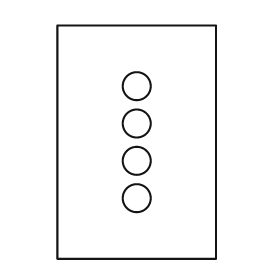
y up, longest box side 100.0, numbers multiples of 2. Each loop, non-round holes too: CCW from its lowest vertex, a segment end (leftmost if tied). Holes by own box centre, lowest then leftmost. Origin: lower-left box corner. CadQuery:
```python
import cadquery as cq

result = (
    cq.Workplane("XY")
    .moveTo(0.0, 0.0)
    .lineTo(68.0, 0.0)
    .lineTo(68.0, 100.0)
    .lineTo(0.0, 100.0)
    .close()
    .moveTo(34.0, 26.0)
    .circle(6.0)
    .moveTo(34.0, 42.0)
    .circle(6.0)
    .moveTo(34.0, 58.0)
    .circle(6.0)
    .moveTo(34.0, 74.0)
    .circle(6.0)
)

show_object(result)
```